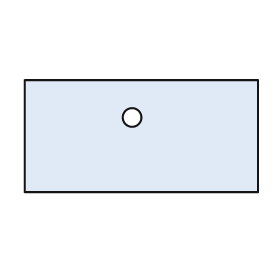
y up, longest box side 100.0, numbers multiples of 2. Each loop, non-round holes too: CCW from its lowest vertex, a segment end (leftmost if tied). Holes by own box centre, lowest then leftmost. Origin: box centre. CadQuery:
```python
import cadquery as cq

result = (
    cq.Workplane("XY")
    .moveTo(-50.0, -24.0)
    .lineTo(50.0, -24.0)
    .lineTo(50.0, 24.0)
    .lineTo(-50.0, 24.0)
    .close()
    .moveTo(-4.0, 8.0)
    .circle(4.0)
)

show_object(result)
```